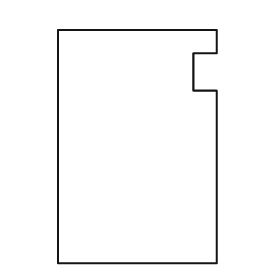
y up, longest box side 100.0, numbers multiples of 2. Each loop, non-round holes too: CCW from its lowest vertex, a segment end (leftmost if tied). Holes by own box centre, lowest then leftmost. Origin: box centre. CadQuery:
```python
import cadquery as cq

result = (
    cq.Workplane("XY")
    .moveTo(-34.0, -50.0)
    .lineTo(34.0, -50.0)
    .lineTo(34.0, 24.0)
    .lineTo(24.0, 24.0)
    .lineTo(24.0, 40.0)
    .lineTo(34.0, 40.0)
    .lineTo(34.0, 50.0)
    .lineTo(-34.0, 50.0)
    .close()
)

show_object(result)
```